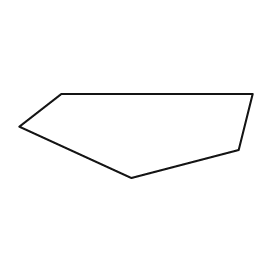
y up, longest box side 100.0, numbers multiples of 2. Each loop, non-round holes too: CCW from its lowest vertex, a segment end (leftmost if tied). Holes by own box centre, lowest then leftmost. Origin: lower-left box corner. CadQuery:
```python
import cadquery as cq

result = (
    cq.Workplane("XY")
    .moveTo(48.0, 0.0)
    .lineTo(94.0, 12.0)
    .lineTo(100.0, 36.0)
    .lineTo(18.0, 36.0)
    .lineTo(0.0, 22.0)
    .close()
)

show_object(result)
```